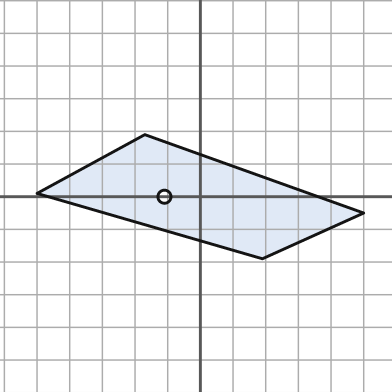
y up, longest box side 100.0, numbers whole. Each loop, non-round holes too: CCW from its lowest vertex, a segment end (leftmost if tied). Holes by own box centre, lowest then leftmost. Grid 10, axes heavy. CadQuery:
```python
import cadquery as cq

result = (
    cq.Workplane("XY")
    .moveTo(19.0, -19.0)
    .lineTo(50.0, -5.0)
    .lineTo(-17.0, 19.0)
    .lineTo(-50.0, 1.0)
    .close()
    .moveTo(-11.0, 0.0)
    .circle(2.0)
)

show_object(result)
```